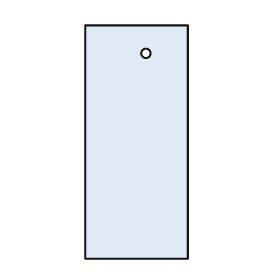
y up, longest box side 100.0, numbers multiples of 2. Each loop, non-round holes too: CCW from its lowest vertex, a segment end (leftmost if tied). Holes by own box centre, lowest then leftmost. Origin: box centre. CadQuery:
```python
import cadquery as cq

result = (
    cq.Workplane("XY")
    .moveTo(-22.0, -50.0)
    .lineTo(22.0, -50.0)
    .lineTo(22.0, 50.0)
    .lineTo(-22.0, 50.0)
    .close()
    .moveTo(4.0, 38.0)
    .circle(2.0)
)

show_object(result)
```